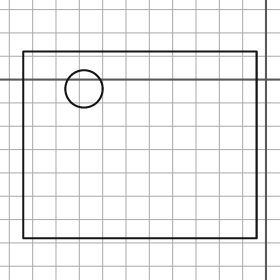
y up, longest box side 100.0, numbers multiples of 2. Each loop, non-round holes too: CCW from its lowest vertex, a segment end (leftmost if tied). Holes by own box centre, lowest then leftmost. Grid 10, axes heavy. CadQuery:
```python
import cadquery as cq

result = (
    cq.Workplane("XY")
    .moveTo(-104.0, -68.0)
    .lineTo(-4.0, -68.0)
    .lineTo(-4.0, 12.0)
    .lineTo(-104.0, 12.0)
    .close()
    .moveTo(-78.0, -4.0)
    .circle(8.0)
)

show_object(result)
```